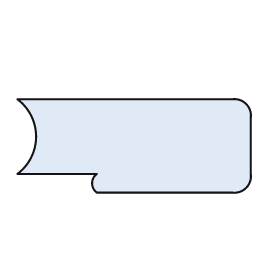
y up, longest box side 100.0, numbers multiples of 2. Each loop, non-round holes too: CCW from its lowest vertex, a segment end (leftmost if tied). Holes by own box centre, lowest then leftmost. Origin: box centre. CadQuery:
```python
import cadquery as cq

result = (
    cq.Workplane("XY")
    .moveTo(-16.0, -20.0)
    .lineTo(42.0, -20.0)
    .threePointArc((48.0, -18.0), (50.0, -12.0))
    .lineTo(50.0, 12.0)
    .threePointArc((48.0, 18.0), (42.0, 20.0))
    .lineTo(-50.0, 20.0)
    .threePointArc((-42.0, 4.0), (-50.0, -12.0))
    .lineTo(-16.0, -12.0)
    .threePointArc((-18.0, -16.0), (-16.0, -20.0))
    .close()
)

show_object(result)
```